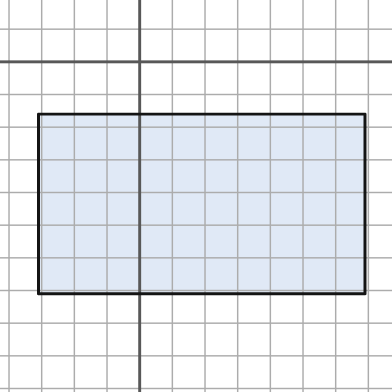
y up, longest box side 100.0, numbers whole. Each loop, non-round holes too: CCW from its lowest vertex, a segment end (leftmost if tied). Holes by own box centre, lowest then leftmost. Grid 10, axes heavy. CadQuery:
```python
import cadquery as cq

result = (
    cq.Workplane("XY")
    .moveTo(-31.0, -71.0)
    .lineTo(69.0, -71.0)
    .lineTo(69.0, -16.0)
    .lineTo(-31.0, -16.0)
    .close()
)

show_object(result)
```